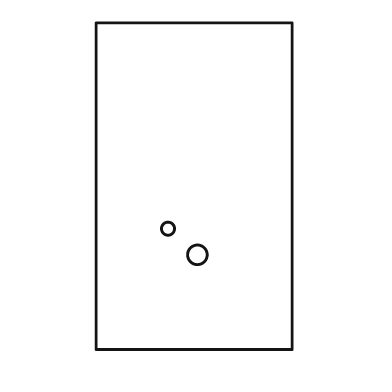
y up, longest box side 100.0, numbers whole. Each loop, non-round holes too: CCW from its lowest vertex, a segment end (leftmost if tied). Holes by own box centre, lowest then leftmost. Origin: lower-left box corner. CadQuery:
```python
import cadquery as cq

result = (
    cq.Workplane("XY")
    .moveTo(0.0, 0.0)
    .lineTo(60.0, 0.0)
    .lineTo(60.0, 100.0)
    .lineTo(0.0, 100.0)
    .close()
    .moveTo(31.0, 29.0)
    .circle(3.0)
    .moveTo(22.0, 37.0)
    .circle(2.0)
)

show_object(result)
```